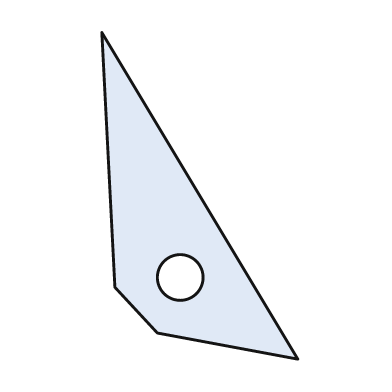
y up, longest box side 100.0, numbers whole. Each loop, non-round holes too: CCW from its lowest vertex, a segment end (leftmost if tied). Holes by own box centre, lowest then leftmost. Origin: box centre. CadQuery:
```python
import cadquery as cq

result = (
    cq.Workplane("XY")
    .moveTo(30.0, -50.0)
    .lineTo(-30.0, 50.0)
    .lineTo(-26.0, -28.0)
    .lineTo(-13.0, -42.0)
    .close()
    .moveTo(-6.0, -25.0)
    .circle(7.0)
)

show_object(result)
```